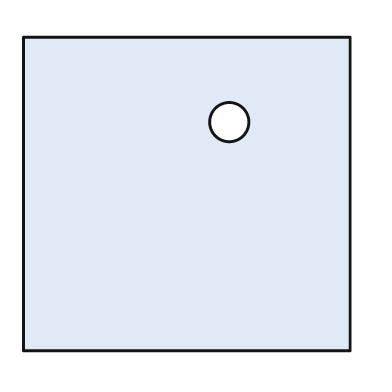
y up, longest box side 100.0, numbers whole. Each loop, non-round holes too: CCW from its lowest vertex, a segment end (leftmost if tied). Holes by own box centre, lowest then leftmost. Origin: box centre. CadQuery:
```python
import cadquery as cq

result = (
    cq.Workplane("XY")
    .moveTo(-50.0, -48.0)
    .lineTo(50.0, -48.0)
    .lineTo(50.0, 48.0)
    .lineTo(-50.0, 48.0)
    .close()
    .moveTo(13.0, 22.0)
    .circle(6.0)
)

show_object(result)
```